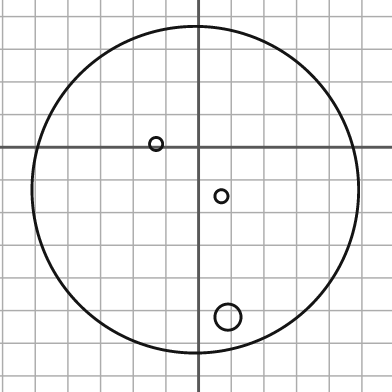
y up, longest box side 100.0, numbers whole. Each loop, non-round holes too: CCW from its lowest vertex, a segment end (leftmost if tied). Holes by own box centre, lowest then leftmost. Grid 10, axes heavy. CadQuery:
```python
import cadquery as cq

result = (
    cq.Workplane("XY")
    .moveTo(-1.0, -13.0)
    .circle(50.0)
    .moveTo(9.0, -52.0)
    .circle(4.0)
    .moveTo(7.0, -15.0)
    .circle(2.0)
    .moveTo(-13.0, 1.0)
    .circle(2.0)
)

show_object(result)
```